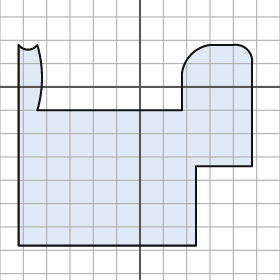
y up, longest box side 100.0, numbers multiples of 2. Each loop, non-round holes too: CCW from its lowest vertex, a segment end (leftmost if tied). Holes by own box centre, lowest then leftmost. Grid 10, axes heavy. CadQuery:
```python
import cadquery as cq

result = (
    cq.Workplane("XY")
    .moveTo(-52.0, -68.0)
    .lineTo(24.0, -68.0)
    .lineTo(24.0, -34.0)
    .lineTo(48.0, -34.0)
    .lineTo(48.0, 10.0)
    .threePointArc((46.0, 16.0), (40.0, 18.0))
    .lineTo(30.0, 18.0)
    .threePointArc((22.0, 14.0), (18.0, 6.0))
    .lineTo(18.0, -10.0)
    .lineTo(-44.0, -10.0)
    .threePointArc((-42.0, 4.0), (-44.0, 18.0))
    .threePointArc((-48.0, 16.0), (-52.0, 18.0))
    .close()
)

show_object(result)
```